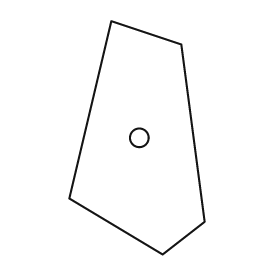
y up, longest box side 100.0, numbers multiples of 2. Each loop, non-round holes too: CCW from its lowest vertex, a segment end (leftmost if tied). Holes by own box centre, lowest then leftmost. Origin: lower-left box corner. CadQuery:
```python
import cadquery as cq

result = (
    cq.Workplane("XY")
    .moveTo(40.0, 0.0)
    .lineTo(58.0, 14.0)
    .lineTo(48.0, 90.0)
    .lineTo(18.0, 100.0)
    .lineTo(0.0, 24.0)
    .close()
    .moveTo(30.0, 50.0)
    .circle(4.0)
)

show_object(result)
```